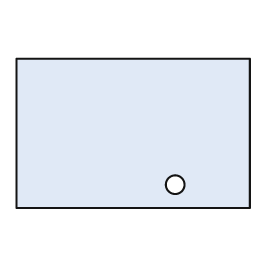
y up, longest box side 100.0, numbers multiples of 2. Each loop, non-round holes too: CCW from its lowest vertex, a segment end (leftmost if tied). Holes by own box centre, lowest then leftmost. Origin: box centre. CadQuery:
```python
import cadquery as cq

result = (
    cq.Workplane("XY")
    .moveTo(-50.0, -32.0)
    .lineTo(50.0, -32.0)
    .lineTo(50.0, 32.0)
    .lineTo(-50.0, 32.0)
    .close()
    .moveTo(18.0, -22.0)
    .circle(4.0)
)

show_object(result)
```